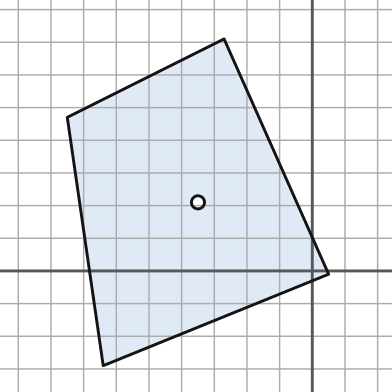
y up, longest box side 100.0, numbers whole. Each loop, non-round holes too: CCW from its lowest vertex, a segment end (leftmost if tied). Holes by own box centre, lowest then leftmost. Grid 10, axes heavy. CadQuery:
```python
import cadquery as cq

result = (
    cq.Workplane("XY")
    .moveTo(-64.0, -29.0)
    .lineTo(5.0, -1.0)
    .lineTo(-27.0, 71.0)
    .lineTo(-75.0, 47.0)
    .close()
    .moveTo(-35.0, 21.0)
    .circle(2.0)
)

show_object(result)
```